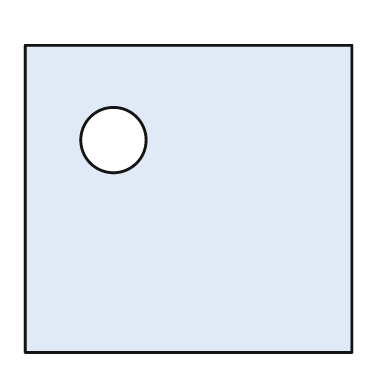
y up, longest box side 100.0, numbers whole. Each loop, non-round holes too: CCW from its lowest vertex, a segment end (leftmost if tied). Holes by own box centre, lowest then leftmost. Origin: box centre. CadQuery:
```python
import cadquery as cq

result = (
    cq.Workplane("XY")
    .moveTo(-50.0, -47.0)
    .lineTo(50.0, -47.0)
    .lineTo(50.0, 47.0)
    .lineTo(-50.0, 47.0)
    .close()
    .moveTo(-23.0, 18.0)
    .circle(10.0)
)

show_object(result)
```